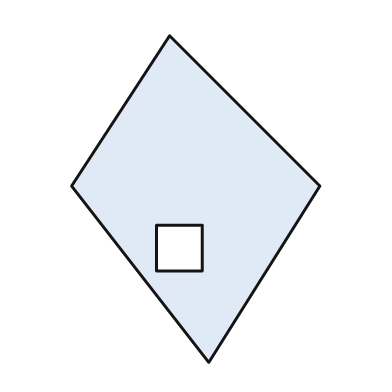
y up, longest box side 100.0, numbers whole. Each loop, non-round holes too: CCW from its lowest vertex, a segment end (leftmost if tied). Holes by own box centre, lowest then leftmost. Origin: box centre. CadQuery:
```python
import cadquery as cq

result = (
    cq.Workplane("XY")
    .moveTo(4.0, -50.0)
    .lineTo(38.0, 4.0)
    .lineTo(-8.0, 50.0)
    .lineTo(-38.0, 4.0)
    .close()
    .moveTo(-12.0, -22.0)
    .lineTo(2.0, -22.0)
    .lineTo(2.0, -8.0)
    .lineTo(-12.0, -8.0)
    .close()
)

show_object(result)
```